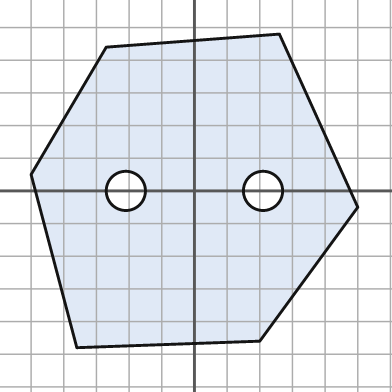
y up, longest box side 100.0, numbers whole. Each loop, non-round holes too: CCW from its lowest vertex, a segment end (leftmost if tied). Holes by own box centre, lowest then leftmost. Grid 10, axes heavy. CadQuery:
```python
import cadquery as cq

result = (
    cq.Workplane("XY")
    .moveTo(-36.0, -48.0)
    .lineTo(20.0, -46.0)
    .lineTo(50.0, -5.0)
    .lineTo(26.0, 48.0)
    .lineTo(-27.0, 44.0)
    .lineTo(-50.0, 5.0)
    .close()
    .moveTo(-21.0, 0.0)
    .circle(6.0)
    .moveTo(21.0, 0.0)
    .circle(6.0)
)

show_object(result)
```